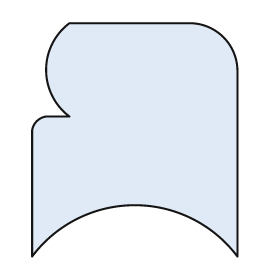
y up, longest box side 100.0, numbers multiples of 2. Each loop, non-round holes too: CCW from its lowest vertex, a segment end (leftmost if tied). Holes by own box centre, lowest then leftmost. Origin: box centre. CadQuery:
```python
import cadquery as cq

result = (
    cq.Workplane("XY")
    .moveTo(-44.0, -50.0)
    .threePointArc((0.0, -28.0), (44.0, -50.0))
    .lineTo(44.0, 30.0)
    .threePointArc((38.0, 44.0), (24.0, 50.0))
    .lineTo(-28.0, 50.0)
    .threePointArc((-38.0, 30.0), (-28.0, 10.0))
    .lineTo(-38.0, 10.0)
    .threePointArc((-42.0, 8.0), (-44.0, 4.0))
    .close()
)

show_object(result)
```